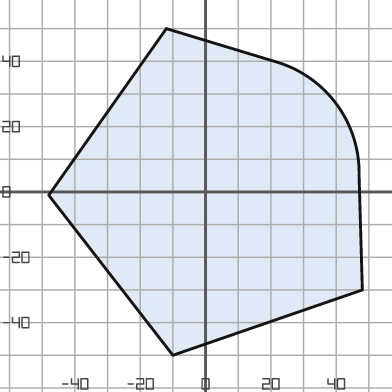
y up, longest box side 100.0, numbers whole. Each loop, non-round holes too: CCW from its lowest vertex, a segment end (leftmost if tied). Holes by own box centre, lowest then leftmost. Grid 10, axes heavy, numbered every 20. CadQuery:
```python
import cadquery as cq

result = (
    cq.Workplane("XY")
    .moveTo(-10.0, -50.0)
    .lineTo(48.0, -30.0)
    .lineTo(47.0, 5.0)
    .threePointArc((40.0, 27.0), (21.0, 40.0))
    .lineTo(-12.0, 50.0)
    .lineTo(-48.0, -1.0)
    .close()
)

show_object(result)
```